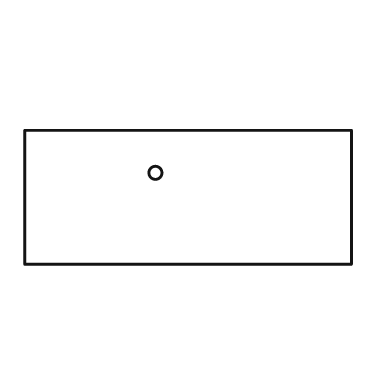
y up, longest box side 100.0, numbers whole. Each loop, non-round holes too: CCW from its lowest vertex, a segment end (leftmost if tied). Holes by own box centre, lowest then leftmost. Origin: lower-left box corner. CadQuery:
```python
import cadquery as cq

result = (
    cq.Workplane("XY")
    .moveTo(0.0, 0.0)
    .lineTo(100.0, 0.0)
    .lineTo(100.0, 41.0)
    .lineTo(0.0, 41.0)
    .close()
    .moveTo(40.0, 28.0)
    .circle(2.0)
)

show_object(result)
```